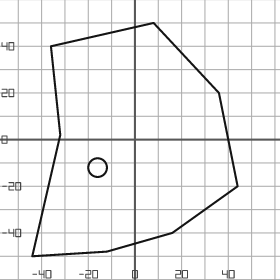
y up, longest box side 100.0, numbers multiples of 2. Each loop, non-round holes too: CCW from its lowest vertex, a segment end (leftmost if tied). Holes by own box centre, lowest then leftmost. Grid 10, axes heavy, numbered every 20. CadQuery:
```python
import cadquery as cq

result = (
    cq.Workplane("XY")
    .moveTo(-44.0, -50.0)
    .lineTo(-12.0, -48.0)
    .lineTo(16.0, -40.0)
    .lineTo(44.0, -20.0)
    .lineTo(36.0, 20.0)
    .lineTo(8.0, 50.0)
    .lineTo(-36.0, 40.0)
    .lineTo(-32.0, 2.0)
    .close()
    .moveTo(-16.0, -12.0)
    .circle(4.0)
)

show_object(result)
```